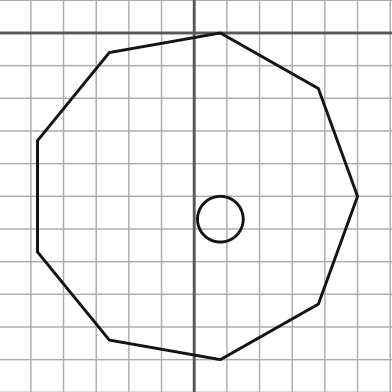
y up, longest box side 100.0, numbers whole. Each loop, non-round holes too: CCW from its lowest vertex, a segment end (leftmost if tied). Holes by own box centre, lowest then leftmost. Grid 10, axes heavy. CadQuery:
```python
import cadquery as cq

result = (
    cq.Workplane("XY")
    .moveTo(8.0, -100.0)
    .lineTo(38.0, -83.0)
    .lineTo(50.0, -50.0)
    .lineTo(38.0, -17.0)
    .lineTo(8.0, 0.0)
    .lineTo(-26.0, -6.0)
    .lineTo(-48.0, -33.0)
    .lineTo(-48.0, -67.0)
    .lineTo(-26.0, -94.0)
    .close()
    .moveTo(8.0, -57.0)
    .circle(7.0)
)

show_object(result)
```